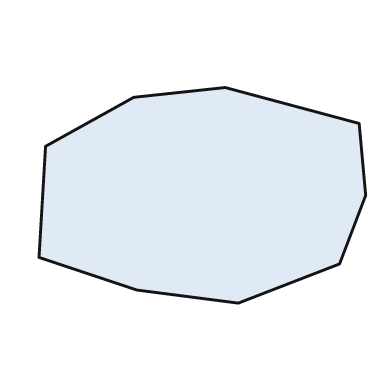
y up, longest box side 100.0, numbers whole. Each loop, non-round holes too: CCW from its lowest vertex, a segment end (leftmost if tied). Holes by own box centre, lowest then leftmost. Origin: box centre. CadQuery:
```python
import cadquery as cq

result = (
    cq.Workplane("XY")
    .moveTo(11.0, -33.0)
    .lineTo(42.0, -21.0)
    .lineTo(50.0, 0.0)
    .lineTo(48.0, 22.0)
    .lineTo(7.0, 33.0)
    .lineTo(-21.0, 30.0)
    .lineTo(-48.0, 15.0)
    .lineTo(-50.0, -19.0)
    .lineTo(-20.0, -29.0)
    .close()
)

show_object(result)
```